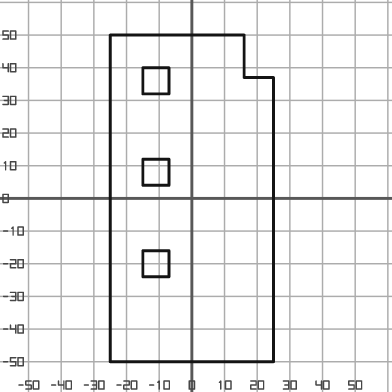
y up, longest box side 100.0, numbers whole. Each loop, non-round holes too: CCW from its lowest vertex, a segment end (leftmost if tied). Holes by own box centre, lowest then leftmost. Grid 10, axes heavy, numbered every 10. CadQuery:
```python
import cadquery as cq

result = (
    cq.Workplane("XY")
    .moveTo(-25.0, -50.0)
    .lineTo(25.0, -50.0)
    .lineTo(25.0, 37.0)
    .lineTo(16.0, 37.0)
    .lineTo(16.0, 50.0)
    .lineTo(-25.0, 50.0)
    .close()
    .moveTo(-15.0, -24.0)
    .lineTo(-7.0, -24.0)
    .lineTo(-7.0, -16.0)
    .lineTo(-15.0, -16.0)
    .close()
    .moveTo(-15.0, 4.0)
    .lineTo(-7.0, 4.0)
    .lineTo(-7.0, 12.0)
    .lineTo(-15.0, 12.0)
    .close()
    .moveTo(-15.0, 32.0)
    .lineTo(-7.0, 32.0)
    .lineTo(-7.0, 40.0)
    .lineTo(-15.0, 40.0)
    .close()
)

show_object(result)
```